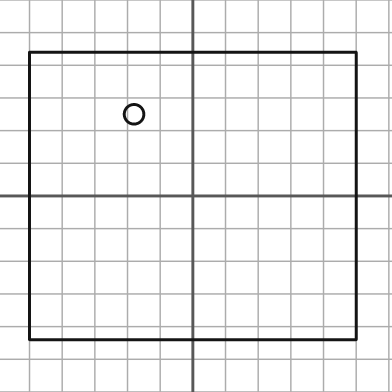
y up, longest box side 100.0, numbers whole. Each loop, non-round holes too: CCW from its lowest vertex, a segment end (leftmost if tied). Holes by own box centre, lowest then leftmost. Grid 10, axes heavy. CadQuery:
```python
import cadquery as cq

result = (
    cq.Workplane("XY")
    .moveTo(-50.0, -44.0)
    .lineTo(50.0, -44.0)
    .lineTo(50.0, 44.0)
    .lineTo(-50.0, 44.0)
    .close()
    .moveTo(-18.0, 25.0)
    .circle(3.0)
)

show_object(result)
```